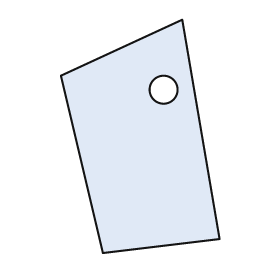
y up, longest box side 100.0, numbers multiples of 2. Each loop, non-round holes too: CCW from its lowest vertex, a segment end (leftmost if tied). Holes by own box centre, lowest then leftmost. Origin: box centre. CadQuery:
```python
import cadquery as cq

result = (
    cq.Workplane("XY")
    .moveTo(-16.0, -50.0)
    .lineTo(34.0, -44.0)
    .lineTo(18.0, 50.0)
    .lineTo(-34.0, 26.0)
    .close()
    .moveTo(10.0, 20.0)
    .circle(6.0)
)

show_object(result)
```